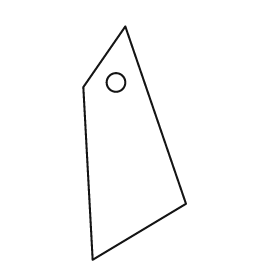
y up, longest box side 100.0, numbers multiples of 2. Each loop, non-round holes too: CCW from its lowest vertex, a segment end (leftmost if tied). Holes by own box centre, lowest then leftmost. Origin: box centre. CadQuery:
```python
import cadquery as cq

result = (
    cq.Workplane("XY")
    .moveTo(-18.0, -50.0)
    .lineTo(22.0, -26.0)
    .lineTo(-4.0, 50.0)
    .lineTo(-22.0, 24.0)
    .close()
    .moveTo(-8.0, 26.0)
    .circle(4.0)
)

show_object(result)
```